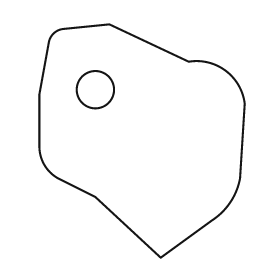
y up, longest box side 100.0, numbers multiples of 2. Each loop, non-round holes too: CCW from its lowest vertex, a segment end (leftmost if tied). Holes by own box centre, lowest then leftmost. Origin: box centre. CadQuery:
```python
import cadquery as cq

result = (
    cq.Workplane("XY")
    .moveTo(8.0, -50.0)
    .lineTo(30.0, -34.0)
    .threePointArc((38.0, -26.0), (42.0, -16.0))
    .lineTo(44.0, 16.0)
    .threePointArc((36.0, 30.0), (20.0, 34.0))
    .lineTo(-14.0, 50.0)
    .lineTo(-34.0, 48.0)
    .threePointArc((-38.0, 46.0), (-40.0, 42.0))
    .lineTo(-44.0, 20.0)
    .lineTo(-44.0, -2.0)
    .threePointArc((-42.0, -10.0), (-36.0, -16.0))
    .lineTo(-20.0, -24.0)
    .close()
    .moveTo(-20.0, 22.0)
    .circle(8.0)
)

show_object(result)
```